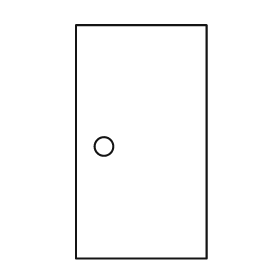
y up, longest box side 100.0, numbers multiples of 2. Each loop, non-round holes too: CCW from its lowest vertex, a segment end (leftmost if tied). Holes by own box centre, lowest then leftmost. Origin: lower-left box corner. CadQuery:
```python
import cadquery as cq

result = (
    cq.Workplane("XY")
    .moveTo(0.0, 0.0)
    .lineTo(56.0, 0.0)
    .lineTo(56.0, 100.0)
    .lineTo(0.0, 100.0)
    .close()
    .moveTo(12.0, 48.0)
    .circle(4.0)
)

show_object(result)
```